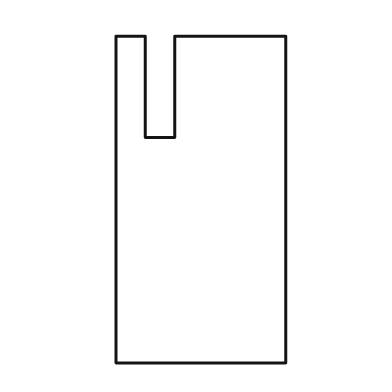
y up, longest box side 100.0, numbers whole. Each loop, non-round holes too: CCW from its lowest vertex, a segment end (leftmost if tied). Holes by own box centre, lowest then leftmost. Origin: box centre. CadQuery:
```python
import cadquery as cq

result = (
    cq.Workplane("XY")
    .moveTo(-26.0, -50.0)
    .lineTo(26.0, -50.0)
    .lineTo(26.0, 50.0)
    .lineTo(-8.0, 50.0)
    .lineTo(-8.0, 19.0)
    .lineTo(-17.0, 19.0)
    .lineTo(-17.0, 50.0)
    .lineTo(-26.0, 50.0)
    .close()
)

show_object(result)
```